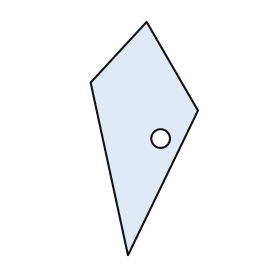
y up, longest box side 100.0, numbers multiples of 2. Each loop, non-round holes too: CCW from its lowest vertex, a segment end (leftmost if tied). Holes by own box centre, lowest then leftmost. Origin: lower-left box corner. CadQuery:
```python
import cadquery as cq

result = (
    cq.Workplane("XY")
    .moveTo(16.0, 0.0)
    .lineTo(46.0, 62.0)
    .lineTo(24.0, 100.0)
    .lineTo(0.0, 74.0)
    .close()
    .moveTo(30.0, 50.0)
    .circle(4.0)
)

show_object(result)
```